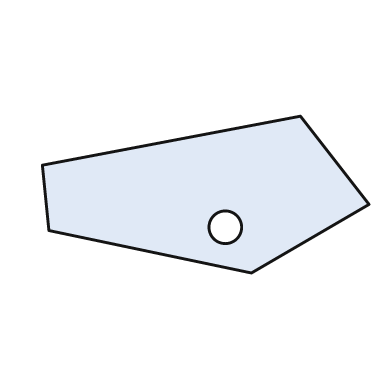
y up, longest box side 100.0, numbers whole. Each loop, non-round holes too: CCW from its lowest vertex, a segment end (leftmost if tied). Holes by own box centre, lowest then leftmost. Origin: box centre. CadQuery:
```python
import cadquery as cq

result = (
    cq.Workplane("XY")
    .moveTo(14.0, -24.0)
    .lineTo(50.0, -3.0)
    .lineTo(29.0, 24.0)
    .lineTo(-50.0, 9.0)
    .lineTo(-48.0, -11.0)
    .close()
    .moveTo(6.0, -10.0)
    .circle(5.0)
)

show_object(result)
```